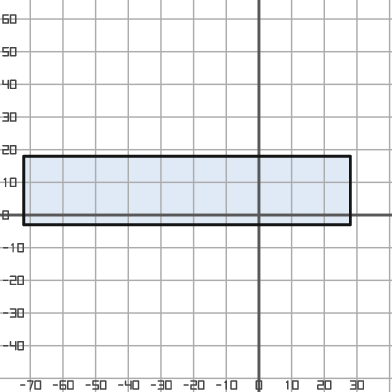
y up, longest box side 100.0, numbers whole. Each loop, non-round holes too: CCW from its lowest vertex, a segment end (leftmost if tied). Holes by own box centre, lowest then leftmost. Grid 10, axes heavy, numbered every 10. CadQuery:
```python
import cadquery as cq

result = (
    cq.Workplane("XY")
    .moveTo(-72.0, -3.0)
    .lineTo(28.0, -3.0)
    .lineTo(28.0, 18.0)
    .lineTo(-72.0, 18.0)
    .close()
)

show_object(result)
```